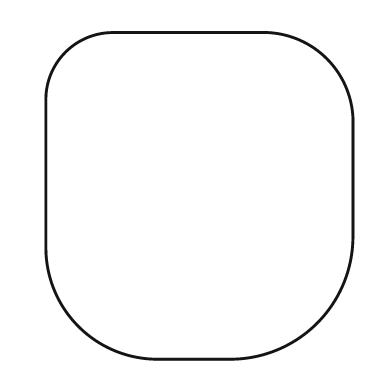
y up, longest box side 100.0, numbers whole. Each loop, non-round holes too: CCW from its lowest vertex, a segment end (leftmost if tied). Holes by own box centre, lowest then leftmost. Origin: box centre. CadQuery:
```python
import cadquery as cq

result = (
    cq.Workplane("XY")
    .moveTo(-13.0, -50.0)
    .lineTo(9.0, -50.0)
    .threePointArc((36.0, -39.0), (47.0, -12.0))
    .lineTo(47.0, 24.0)
    .threePointArc((39.0, 42.0), (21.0, 50.0))
    .lineTo(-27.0, 50.0)
    .threePointArc((-41.0, 44.0), (-47.0, 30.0))
    .lineTo(-47.0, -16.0)
    .threePointArc((-37.0, -40.0), (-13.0, -50.0))
    .close()
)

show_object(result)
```